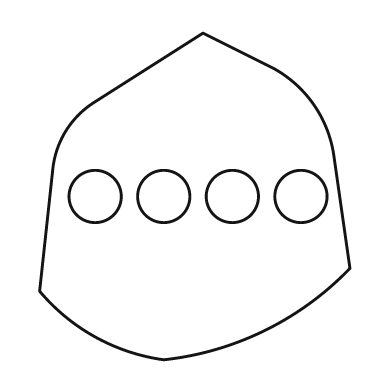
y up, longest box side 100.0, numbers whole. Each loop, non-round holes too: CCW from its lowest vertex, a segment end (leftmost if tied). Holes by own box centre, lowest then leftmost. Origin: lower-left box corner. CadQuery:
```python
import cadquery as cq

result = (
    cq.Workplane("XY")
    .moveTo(38.0, 0.0)
    .threePointArc((69.0, 9.0), (95.0, 28.0))
    .lineTo(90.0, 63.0)
    .threePointArc((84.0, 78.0), (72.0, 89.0))
    .lineTo(50.0, 100.0)
    .lineTo(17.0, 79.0)
    .threePointArc((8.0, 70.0), (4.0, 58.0))
    .lineTo(0.0, 21.0)
    .threePointArc((17.0, 7.0), (38.0, 0.0))
    .close()
    .moveTo(17.0, 50.0)
    .circle(8.0)
    .moveTo(38.0, 50.0)
    .circle(8.0)
    .moveTo(59.0, 50.0)
    .circle(8.0)
    .moveTo(80.0, 50.0)
    .circle(8.0)
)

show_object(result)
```